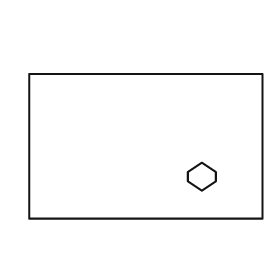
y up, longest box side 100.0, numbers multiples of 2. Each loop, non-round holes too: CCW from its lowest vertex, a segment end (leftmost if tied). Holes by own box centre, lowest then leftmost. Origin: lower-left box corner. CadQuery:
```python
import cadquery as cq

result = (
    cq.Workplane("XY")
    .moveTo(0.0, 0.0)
    .lineTo(100.0, 0.0)
    .lineTo(100.0, 62.0)
    .lineTo(0.0, 62.0)
    .close()
    .moveTo(74.0, 12.0)
    .lineTo(80.0, 16.0)
    .lineTo(80.0, 20.0)
    .lineTo(74.0, 24.0)
    .lineTo(68.0, 20.0)
    .lineTo(68.0, 16.0)
    .close()
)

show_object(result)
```